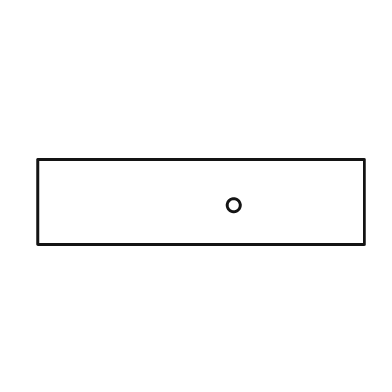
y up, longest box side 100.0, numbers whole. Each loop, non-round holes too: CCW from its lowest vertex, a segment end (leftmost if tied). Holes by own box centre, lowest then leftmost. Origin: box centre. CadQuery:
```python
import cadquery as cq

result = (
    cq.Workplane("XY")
    .moveTo(-50.0, -13.0)
    .lineTo(50.0, -13.0)
    .lineTo(50.0, 13.0)
    .lineTo(-50.0, 13.0)
    .close()
    .moveTo(10.0, -1.0)
    .circle(2.0)
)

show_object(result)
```